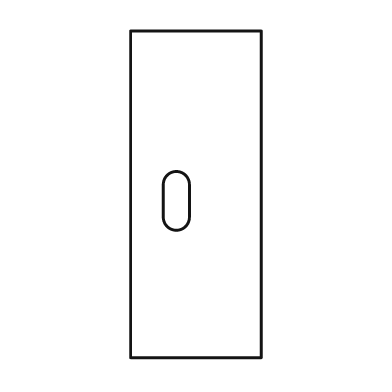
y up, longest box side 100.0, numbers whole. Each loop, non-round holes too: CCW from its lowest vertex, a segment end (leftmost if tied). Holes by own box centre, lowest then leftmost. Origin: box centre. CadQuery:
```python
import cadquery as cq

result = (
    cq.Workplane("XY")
    .moveTo(-20.0, -50.0)
    .lineTo(20.0, -50.0)
    .lineTo(20.0, 50.0)
    .lineTo(-20.0, 50.0)
    .close()
    .moveTo(-10.0, -7.0)
    .threePointArc((-6.0, -11.0), (-2.0, -7.0))
    .lineTo(-2.0, 3.0)
    .threePointArc((-6.0, 7.0), (-10.0, 3.0))
    .close()
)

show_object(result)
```